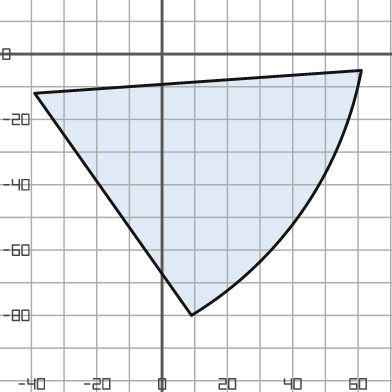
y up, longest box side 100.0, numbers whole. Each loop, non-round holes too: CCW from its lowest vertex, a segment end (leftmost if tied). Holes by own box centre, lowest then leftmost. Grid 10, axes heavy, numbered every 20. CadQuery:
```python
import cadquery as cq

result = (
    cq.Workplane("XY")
    .moveTo(9.0, -80.0)
    .threePointArc((43.0, -48.0), (61.0, -5.0))
    .lineTo(-39.0, -12.0)
    .close()
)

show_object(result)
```